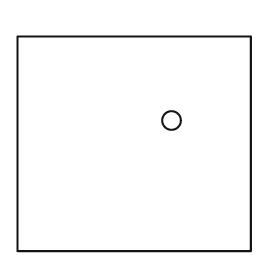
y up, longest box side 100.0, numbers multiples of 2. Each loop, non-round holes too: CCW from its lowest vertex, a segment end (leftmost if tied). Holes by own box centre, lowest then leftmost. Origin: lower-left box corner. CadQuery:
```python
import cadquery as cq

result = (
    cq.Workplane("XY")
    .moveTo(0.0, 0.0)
    .lineTo(100.0, 0.0)
    .lineTo(100.0, 92.0)
    .lineTo(0.0, 92.0)
    .close()
    .moveTo(66.0, 56.0)
    .circle(4.0)
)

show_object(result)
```